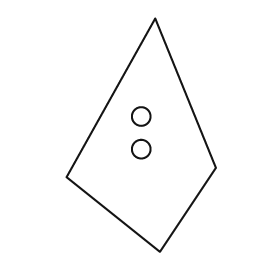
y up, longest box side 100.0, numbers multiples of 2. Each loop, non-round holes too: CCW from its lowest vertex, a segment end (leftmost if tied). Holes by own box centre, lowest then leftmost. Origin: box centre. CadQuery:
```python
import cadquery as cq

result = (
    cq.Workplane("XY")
    .moveTo(8.0, -50.0)
    .lineTo(32.0, -14.0)
    .lineTo(6.0, 50.0)
    .lineTo(-32.0, -18.0)
    .close()
    .moveTo(0.0, -6.0)
    .circle(4.0)
    .moveTo(0.0, 8.0)
    .circle(4.0)
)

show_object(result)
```